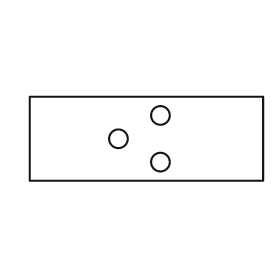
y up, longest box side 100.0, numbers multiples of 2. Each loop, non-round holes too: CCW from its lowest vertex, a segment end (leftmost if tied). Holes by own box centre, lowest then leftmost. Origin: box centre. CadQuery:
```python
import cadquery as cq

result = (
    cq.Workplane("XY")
    .moveTo(-50.0, -18.0)
    .lineTo(50.0, -18.0)
    .lineTo(50.0, 18.0)
    .lineTo(-50.0, 18.0)
    .close()
    .moveTo(6.0, -10.0)
    .circle(4.0)
    .moveTo(-12.0, 0.0)
    .circle(4.0)
    .moveTo(6.0, 10.0)
    .circle(4.0)
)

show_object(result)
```